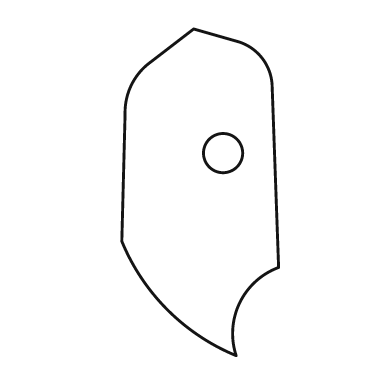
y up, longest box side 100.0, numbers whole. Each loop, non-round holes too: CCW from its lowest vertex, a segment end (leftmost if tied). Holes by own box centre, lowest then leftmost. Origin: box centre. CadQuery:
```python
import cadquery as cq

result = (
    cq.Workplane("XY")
    .moveTo(11.0, -50.0)
    .threePointArc((12.0, -34.0), (24.0, -23.0))
    .lineTo(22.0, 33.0)
    .threePointArc((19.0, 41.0), (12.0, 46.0))
    .lineTo(-2.0, 50.0)
    .lineTo(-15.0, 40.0)
    .threePointArc((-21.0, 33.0), (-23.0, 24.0))
    .lineTo(-24.0, -15.0)
    .threePointArc((-10.0, -36.0), (11.0, -50.0))
    .close()
    .moveTo(7.0, 12.0)
    .circle(6.0)
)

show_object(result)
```